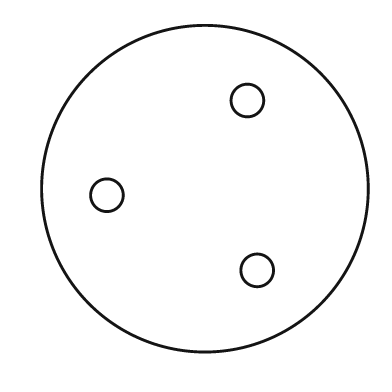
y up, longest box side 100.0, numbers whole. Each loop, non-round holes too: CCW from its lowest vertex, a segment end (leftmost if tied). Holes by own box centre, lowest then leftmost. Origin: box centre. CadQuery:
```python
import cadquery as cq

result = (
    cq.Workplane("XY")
    .moveTo(0.0, 0.0)
    .circle(50.0)
    .moveTo(16.0, -25.0)
    .circle(5.0)
    .moveTo(-30.0, -2.0)
    .circle(5.0)
    .moveTo(13.0, 27.0)
    .circle(5.0)
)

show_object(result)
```